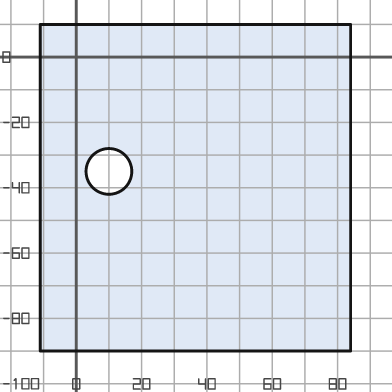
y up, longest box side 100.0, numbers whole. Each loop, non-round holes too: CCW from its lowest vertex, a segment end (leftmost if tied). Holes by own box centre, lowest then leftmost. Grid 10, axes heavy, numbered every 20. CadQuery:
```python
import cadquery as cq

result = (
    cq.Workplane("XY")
    .moveTo(-11.0, -90.0)
    .lineTo(84.0, -90.0)
    .lineTo(84.0, 10.0)
    .lineTo(-11.0, 10.0)
    .close()
    .moveTo(10.0, -35.0)
    .circle(7.0)
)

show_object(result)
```